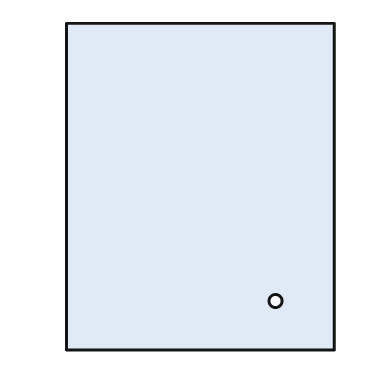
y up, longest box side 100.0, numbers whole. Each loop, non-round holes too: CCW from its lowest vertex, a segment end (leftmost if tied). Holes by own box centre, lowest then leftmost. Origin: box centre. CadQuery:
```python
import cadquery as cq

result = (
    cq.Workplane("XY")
    .moveTo(-41.0, -50.0)
    .lineTo(41.0, -50.0)
    .lineTo(41.0, 50.0)
    .lineTo(-41.0, 50.0)
    .close()
    .moveTo(23.0, -35.0)
    .circle(2.0)
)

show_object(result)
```